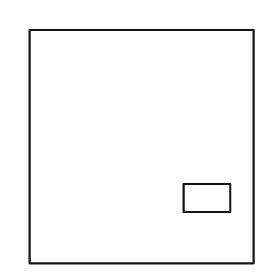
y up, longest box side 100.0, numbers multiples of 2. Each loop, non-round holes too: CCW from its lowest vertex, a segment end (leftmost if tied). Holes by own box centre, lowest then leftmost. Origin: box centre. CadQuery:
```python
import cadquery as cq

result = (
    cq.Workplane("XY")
    .moveTo(-48.0, -50.0)
    .lineTo(48.0, -50.0)
    .lineTo(48.0, 50.0)
    .lineTo(-48.0, 50.0)
    .close()
    .moveTo(18.0, -28.0)
    .lineTo(38.0, -28.0)
    .lineTo(38.0, -16.0)
    .lineTo(18.0, -16.0)
    .close()
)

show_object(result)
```